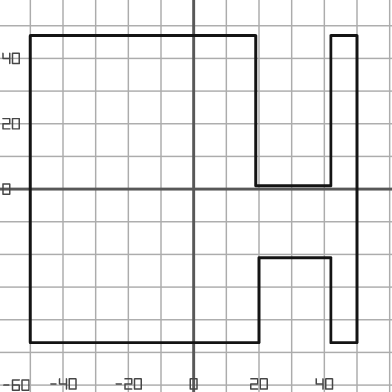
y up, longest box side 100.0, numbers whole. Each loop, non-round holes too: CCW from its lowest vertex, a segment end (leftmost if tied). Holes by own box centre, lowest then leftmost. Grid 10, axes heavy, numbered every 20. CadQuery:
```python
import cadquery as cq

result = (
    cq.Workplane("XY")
    .moveTo(-50.0, -47.0)
    .lineTo(20.0, -47.0)
    .lineTo(20.0, -21.0)
    .lineTo(42.0, -21.0)
    .lineTo(42.0, -47.0)
    .lineTo(50.0, -47.0)
    .lineTo(50.0, 47.0)
    .lineTo(42.0, 47.0)
    .lineTo(42.0, 1.0)
    .lineTo(19.0, 1.0)
    .lineTo(19.0, 47.0)
    .lineTo(-50.0, 47.0)
    .close()
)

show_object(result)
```